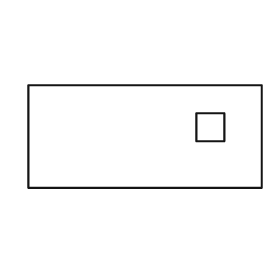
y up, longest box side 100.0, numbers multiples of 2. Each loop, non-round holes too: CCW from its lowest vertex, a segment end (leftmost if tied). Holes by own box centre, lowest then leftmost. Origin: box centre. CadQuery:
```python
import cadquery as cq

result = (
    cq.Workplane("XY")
    .moveTo(-50.0, -22.0)
    .lineTo(50.0, -22.0)
    .lineTo(50.0, 22.0)
    .lineTo(-50.0, 22.0)
    .close()
    .moveTo(22.0, -2.0)
    .lineTo(34.0, -2.0)
    .lineTo(34.0, 10.0)
    .lineTo(22.0, 10.0)
    .close()
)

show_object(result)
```